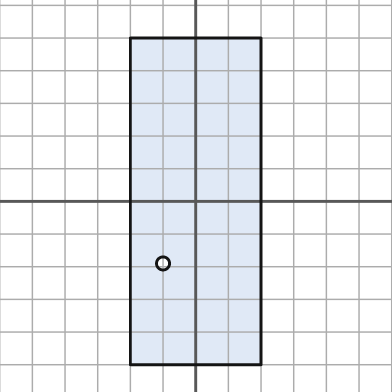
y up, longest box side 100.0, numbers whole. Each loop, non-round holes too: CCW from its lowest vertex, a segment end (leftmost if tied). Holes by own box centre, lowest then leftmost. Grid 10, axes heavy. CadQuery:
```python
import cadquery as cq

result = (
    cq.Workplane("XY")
    .moveTo(-20.0, -50.0)
    .lineTo(20.0, -50.0)
    .lineTo(20.0, 50.0)
    .lineTo(-20.0, 50.0)
    .close()
    .moveTo(-10.0, -19.0)
    .circle(2.0)
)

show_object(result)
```